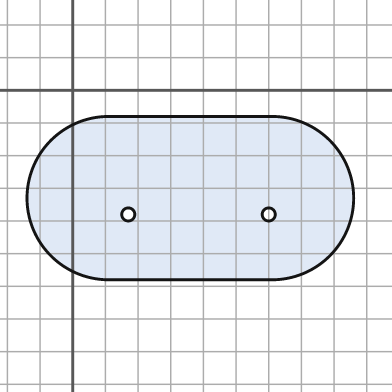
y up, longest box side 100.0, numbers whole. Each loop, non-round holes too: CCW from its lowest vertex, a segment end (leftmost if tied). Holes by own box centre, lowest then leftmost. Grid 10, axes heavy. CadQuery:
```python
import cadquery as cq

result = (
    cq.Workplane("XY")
    .moveTo(11.0, -58.0)
    .lineTo(61.0, -58.0)
    .threePointArc((86.0, -33.0), (61.0, -8.0))
    .lineTo(11.0, -8.0)
    .threePointArc((-14.0, -33.0), (11.0, -58.0))
    .close()
    .moveTo(17.0, -38.0)
    .circle(2.0)
    .moveTo(60.0, -38.0)
    .circle(2.0)
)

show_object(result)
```